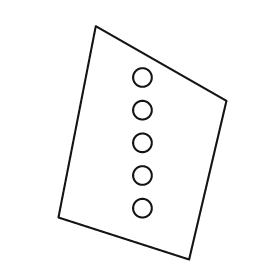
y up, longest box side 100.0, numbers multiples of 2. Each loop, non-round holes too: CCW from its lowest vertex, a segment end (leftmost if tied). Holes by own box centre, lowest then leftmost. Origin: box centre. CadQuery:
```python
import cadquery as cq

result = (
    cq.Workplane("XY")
    .moveTo(20.0, -50.0)
    .lineTo(36.0, 18.0)
    .lineTo(-20.0, 50.0)
    .lineTo(-36.0, -32.0)
    .close()
    .moveTo(0.0, -28.0)
    .circle(4.0)
    .moveTo(0.0, -14.0)
    .circle(4.0)
    .moveTo(0.0, 0.0)
    .circle(4.0)
    .moveTo(0.0, 14.0)
    .circle(4.0)
    .moveTo(0.0, 28.0)
    .circle(4.0)
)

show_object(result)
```